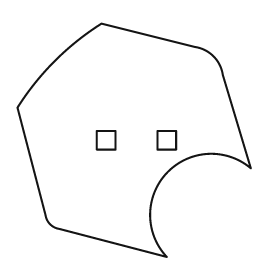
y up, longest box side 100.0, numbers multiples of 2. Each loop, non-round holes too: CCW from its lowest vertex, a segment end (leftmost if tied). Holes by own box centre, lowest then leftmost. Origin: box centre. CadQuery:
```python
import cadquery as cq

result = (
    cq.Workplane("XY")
    .moveTo(14.0, -50.0)
    .threePointArc((14.0, -14.0), (50.0, -12.0))
    .lineTo(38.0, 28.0)
    .threePointArc((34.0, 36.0), (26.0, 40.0))
    .lineTo(-14.0, 50.0)
    .threePointArc((-34.0, 34.0), (-50.0, 14.0))
    .lineTo(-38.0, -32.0)
    .threePointArc((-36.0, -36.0), (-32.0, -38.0))
    .close()
    .moveTo(-16.0, -4.0)
    .lineTo(-8.0, -4.0)
    .lineTo(-8.0, 4.0)
    .lineTo(-16.0, 4.0)
    .close()
    .moveTo(10.0, -4.0)
    .lineTo(18.0, -4.0)
    .lineTo(18.0, 4.0)
    .lineTo(10.0, 4.0)
    .close()
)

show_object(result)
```